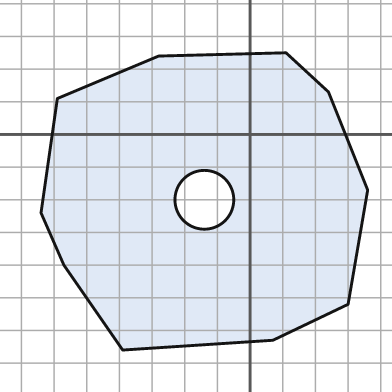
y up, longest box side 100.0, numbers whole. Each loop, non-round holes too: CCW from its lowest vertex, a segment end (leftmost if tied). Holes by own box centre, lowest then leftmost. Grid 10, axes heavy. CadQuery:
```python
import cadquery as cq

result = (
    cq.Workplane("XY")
    .moveTo(-39.0, -66.0)
    .lineTo(7.0, -63.0)
    .lineTo(30.0, -52.0)
    .lineTo(36.0, -17.0)
    .lineTo(24.0, 13.0)
    .lineTo(11.0, 25.0)
    .lineTo(-28.0, 24.0)
    .lineTo(-59.0, 11.0)
    .lineTo(-64.0, -24.0)
    .lineTo(-57.0, -40.0)
    .close()
    .moveTo(-14.0, -20.0)
    .circle(9.0)
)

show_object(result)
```